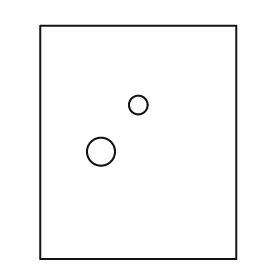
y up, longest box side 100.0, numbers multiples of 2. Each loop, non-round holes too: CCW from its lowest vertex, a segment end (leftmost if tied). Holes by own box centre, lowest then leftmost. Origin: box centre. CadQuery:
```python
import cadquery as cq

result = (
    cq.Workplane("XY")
    .moveTo(-42.0, -50.0)
    .lineTo(42.0, -50.0)
    .lineTo(42.0, 50.0)
    .lineTo(-42.0, 50.0)
    .close()
    .moveTo(-16.0, -4.0)
    .circle(6.0)
    .moveTo(0.0, 16.0)
    .circle(4.0)
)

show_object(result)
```